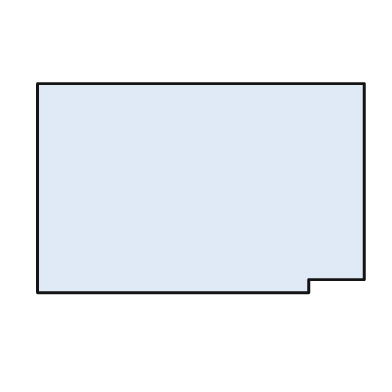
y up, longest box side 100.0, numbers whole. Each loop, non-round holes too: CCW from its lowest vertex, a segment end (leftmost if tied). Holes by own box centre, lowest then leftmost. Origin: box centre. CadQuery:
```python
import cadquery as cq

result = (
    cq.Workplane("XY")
    .moveTo(-50.0, -32.0)
    .lineTo(33.0, -32.0)
    .lineTo(33.0, -28.0)
    .lineTo(50.0, -28.0)
    .lineTo(50.0, 32.0)
    .lineTo(-50.0, 32.0)
    .close()
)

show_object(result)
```